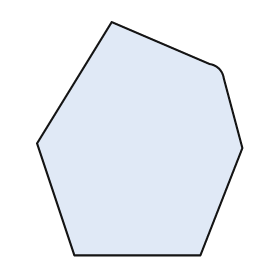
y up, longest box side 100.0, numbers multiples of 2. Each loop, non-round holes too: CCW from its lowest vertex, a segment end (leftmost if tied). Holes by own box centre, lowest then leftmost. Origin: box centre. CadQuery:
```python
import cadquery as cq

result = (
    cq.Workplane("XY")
    .moveTo(-28.0, -50.0)
    .lineTo(26.0, -50.0)
    .lineTo(44.0, -4.0)
    .lineTo(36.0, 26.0)
    .threePointArc((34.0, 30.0), (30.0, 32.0))
    .lineTo(-12.0, 50.0)
    .lineTo(-44.0, -2.0)
    .close()
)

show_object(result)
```